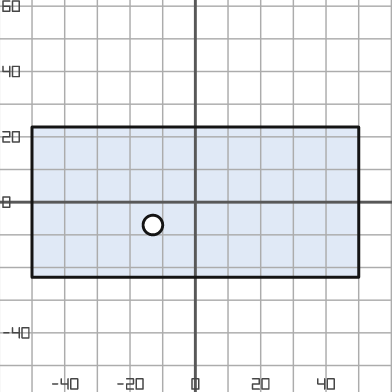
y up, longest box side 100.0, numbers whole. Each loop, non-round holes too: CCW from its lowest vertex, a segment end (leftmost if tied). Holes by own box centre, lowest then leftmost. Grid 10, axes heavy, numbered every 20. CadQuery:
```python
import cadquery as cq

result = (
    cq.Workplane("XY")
    .moveTo(-50.0, -23.0)
    .lineTo(50.0, -23.0)
    .lineTo(50.0, 23.0)
    .lineTo(-50.0, 23.0)
    .close()
    .moveTo(-13.0, -7.0)
    .circle(3.0)
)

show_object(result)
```